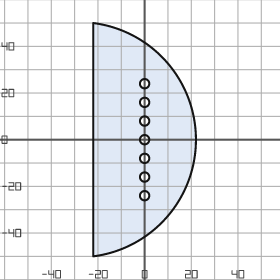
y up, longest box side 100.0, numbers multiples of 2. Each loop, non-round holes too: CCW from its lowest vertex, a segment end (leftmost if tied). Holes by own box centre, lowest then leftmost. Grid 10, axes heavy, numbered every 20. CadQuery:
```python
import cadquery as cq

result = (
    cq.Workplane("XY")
    .moveTo(-22.0, -50.0)
    .threePointArc((22.0, 0.0), (-22.0, 50.0))
    .close()
    .moveTo(0.0, -24.0)
    .circle(2.0)
    .moveTo(0.0, -16.0)
    .circle(2.0)
    .moveTo(0.0, -8.0)
    .circle(2.0)
    .moveTo(0.0, 0.0)
    .circle(2.0)
    .moveTo(0.0, 8.0)
    .circle(2.0)
    .moveTo(0.0, 16.0)
    .circle(2.0)
    .moveTo(0.0, 24.0)
    .circle(2.0)
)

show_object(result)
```